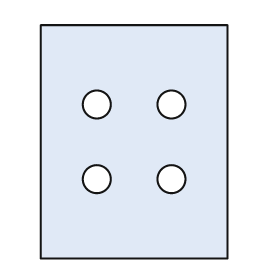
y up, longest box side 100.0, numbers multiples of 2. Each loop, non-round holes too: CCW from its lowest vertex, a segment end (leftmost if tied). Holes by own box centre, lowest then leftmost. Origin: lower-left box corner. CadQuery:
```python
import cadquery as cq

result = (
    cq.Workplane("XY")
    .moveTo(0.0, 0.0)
    .lineTo(80.0, 0.0)
    .lineTo(80.0, 100.0)
    .lineTo(0.0, 100.0)
    .close()
    .moveTo(24.0, 34.0)
    .circle(6.0)
    .moveTo(56.0, 34.0)
    .circle(6.0)
    .moveTo(24.0, 66.0)
    .circle(6.0)
    .moveTo(56.0, 66.0)
    .circle(6.0)
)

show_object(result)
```